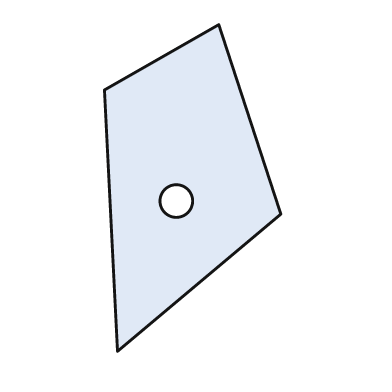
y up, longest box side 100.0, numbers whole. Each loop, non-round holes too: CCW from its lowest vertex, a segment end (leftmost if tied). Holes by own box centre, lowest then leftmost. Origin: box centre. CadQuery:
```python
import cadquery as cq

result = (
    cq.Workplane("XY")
    .moveTo(-23.0, -50.0)
    .lineTo(27.0, -8.0)
    .lineTo(8.0, 50.0)
    .lineTo(-27.0, 30.0)
    .close()
    .moveTo(-5.0, -4.0)
    .circle(5.0)
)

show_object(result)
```